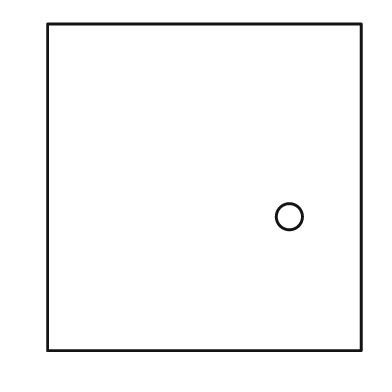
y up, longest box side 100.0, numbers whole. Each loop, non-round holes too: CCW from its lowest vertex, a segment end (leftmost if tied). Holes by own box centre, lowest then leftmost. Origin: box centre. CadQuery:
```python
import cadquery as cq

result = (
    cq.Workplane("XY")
    .moveTo(-48.0, -50.0)
    .lineTo(48.0, -50.0)
    .lineTo(48.0, 50.0)
    .lineTo(-48.0, 50.0)
    .close()
    .moveTo(26.0, -9.0)
    .circle(4.0)
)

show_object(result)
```